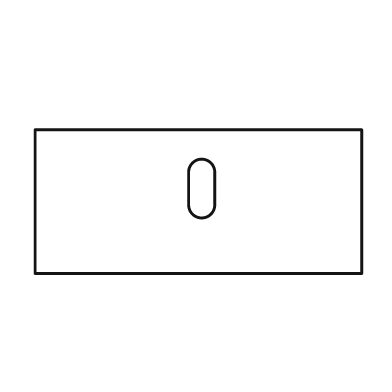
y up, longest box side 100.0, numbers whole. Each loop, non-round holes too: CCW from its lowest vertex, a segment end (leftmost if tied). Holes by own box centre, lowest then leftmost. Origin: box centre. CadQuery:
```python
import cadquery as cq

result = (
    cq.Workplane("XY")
    .moveTo(-50.0, -22.0)
    .lineTo(50.0, -22.0)
    .lineTo(50.0, 22.0)
    .lineTo(-50.0, 22.0)
    .close()
    .moveTo(-3.0, -1.0)
    .threePointArc((1.0, -5.0), (5.0, -1.0))
    .lineTo(5.0, 9.0)
    .threePointArc((1.0, 13.0), (-3.0, 9.0))
    .close()
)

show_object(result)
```